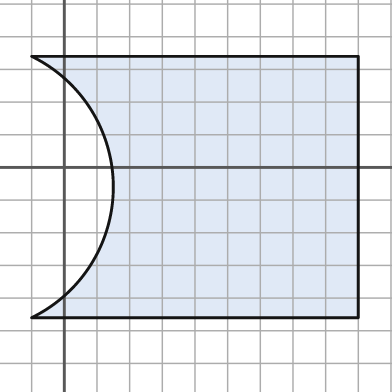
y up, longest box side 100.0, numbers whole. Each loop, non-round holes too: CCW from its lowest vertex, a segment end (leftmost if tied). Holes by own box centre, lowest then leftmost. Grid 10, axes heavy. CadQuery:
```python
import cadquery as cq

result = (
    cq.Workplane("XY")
    .moveTo(-10.0, -46.0)
    .lineTo(90.0, -46.0)
    .lineTo(90.0, 34.0)
    .lineTo(-10.0, 34.0)
    .threePointArc((15.0, -6.0), (-10.0, -46.0))
    .close()
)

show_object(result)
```